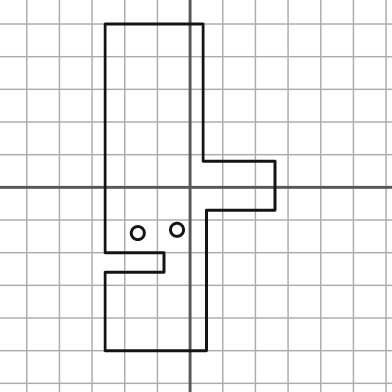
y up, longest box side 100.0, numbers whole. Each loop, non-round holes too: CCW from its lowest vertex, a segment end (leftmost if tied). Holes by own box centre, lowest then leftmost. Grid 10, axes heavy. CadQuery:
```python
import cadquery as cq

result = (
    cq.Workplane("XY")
    .moveTo(-26.0, -50.0)
    .lineTo(5.0, -50.0)
    .lineTo(5.0, -7.0)
    .lineTo(26.0, -7.0)
    .lineTo(26.0, 8.0)
    .lineTo(4.0, 8.0)
    .lineTo(4.0, 50.0)
    .lineTo(-26.0, 50.0)
    .lineTo(-26.0, -20.0)
    .lineTo(-8.0, -20.0)
    .lineTo(-8.0, -26.0)
    .lineTo(-26.0, -26.0)
    .close()
    .moveTo(-16.0, -14.0)
    .circle(2.0)
    .moveTo(-4.0, -13.0)
    .circle(2.0)
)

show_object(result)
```